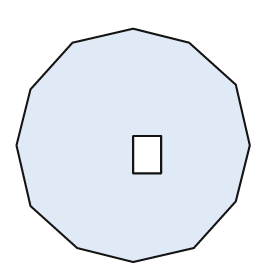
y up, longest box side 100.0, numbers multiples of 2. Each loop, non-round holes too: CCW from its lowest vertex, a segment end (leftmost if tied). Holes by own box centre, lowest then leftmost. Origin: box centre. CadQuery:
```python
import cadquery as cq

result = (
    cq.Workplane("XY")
    .moveTo(0.0, -50.0)
    .lineTo(26.0, -44.0)
    .lineTo(44.0, -24.0)
    .lineTo(50.0, 0.0)
    .lineTo(44.0, 26.0)
    .lineTo(24.0, 44.0)
    .lineTo(0.0, 50.0)
    .lineTo(-26.0, 44.0)
    .lineTo(-44.0, 24.0)
    .lineTo(-50.0, 0.0)
    .lineTo(-44.0, -26.0)
    .lineTo(-24.0, -44.0)
    .close()
    .moveTo(0.0, -12.0)
    .lineTo(12.0, -12.0)
    .lineTo(12.0, 4.0)
    .lineTo(0.0, 4.0)
    .close()
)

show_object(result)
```